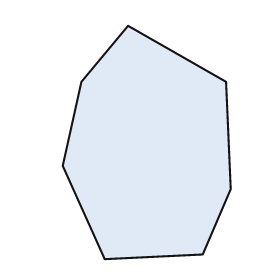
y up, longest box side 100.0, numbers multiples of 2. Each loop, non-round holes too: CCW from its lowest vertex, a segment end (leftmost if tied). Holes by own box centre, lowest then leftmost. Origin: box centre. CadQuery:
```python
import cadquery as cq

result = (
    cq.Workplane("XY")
    .moveTo(-18.0, -50.0)
    .lineTo(24.0, -48.0)
    .lineTo(36.0, -20.0)
    .lineTo(34.0, 26.0)
    .lineTo(-8.0, 50.0)
    .lineTo(-28.0, 26.0)
    .lineTo(-36.0, -10.0)
    .close()
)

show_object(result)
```